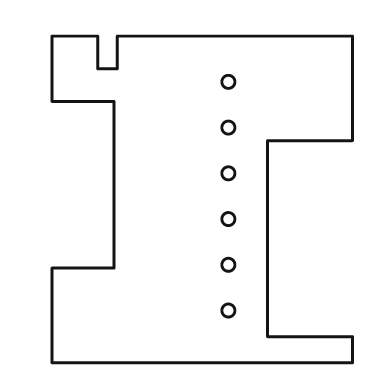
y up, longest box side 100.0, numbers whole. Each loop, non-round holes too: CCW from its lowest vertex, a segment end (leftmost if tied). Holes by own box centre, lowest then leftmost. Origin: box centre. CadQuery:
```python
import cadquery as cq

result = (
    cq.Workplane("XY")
    .moveTo(-46.0, -50.0)
    .lineTo(46.0, -50.0)
    .lineTo(46.0, -42.0)
    .lineTo(20.0, -42.0)
    .lineTo(20.0, 18.0)
    .lineTo(46.0, 18.0)
    .lineTo(46.0, 50.0)
    .lineTo(-26.0, 50.0)
    .lineTo(-26.0, 40.0)
    .lineTo(-32.0, 40.0)
    .lineTo(-32.0, 50.0)
    .lineTo(-46.0, 50.0)
    .lineTo(-46.0, 30.0)
    .lineTo(-27.0, 30.0)
    .lineTo(-27.0, -21.0)
    .lineTo(-46.0, -21.0)
    .close()
    .moveTo(8.0, -34.0)
    .circle(2.0)
    .moveTo(8.0, -20.0)
    .circle(2.0)
    .moveTo(8.0, -6.0)
    .circle(2.0)
    .moveTo(8.0, 8.0)
    .circle(2.0)
    .moveTo(8.0, 22.0)
    .circle(2.0)
    .moveTo(8.0, 36.0)
    .circle(2.0)
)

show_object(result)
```